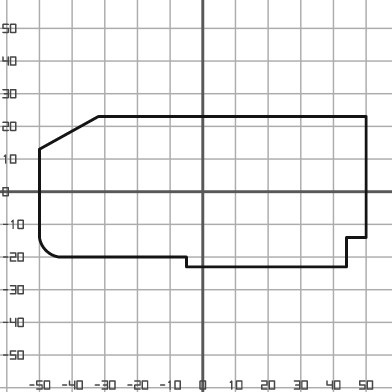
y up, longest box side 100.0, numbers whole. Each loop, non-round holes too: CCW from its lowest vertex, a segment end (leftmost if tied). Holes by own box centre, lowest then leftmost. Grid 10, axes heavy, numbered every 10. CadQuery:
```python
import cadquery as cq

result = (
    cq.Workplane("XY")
    .moveTo(-5.0, -23.0)
    .lineTo(44.0, -23.0)
    .lineTo(44.0, -14.0)
    .lineTo(50.0, -14.0)
    .lineTo(50.0, 23.0)
    .lineTo(-32.0, 23.0)
    .lineTo(-50.0, 13.0)
    .lineTo(-50.0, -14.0)
    .threePointArc((-48.0, -18.0), (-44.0, -20.0))
    .lineTo(-5.0, -20.0)
    .close()
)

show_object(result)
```